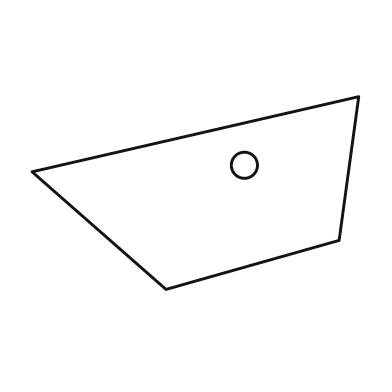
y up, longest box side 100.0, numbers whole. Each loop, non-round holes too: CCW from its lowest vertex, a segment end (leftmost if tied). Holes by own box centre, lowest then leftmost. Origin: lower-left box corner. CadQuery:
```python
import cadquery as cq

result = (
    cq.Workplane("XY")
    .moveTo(41.0, 0.0)
    .lineTo(94.0, 15.0)
    .lineTo(100.0, 59.0)
    .lineTo(0.0, 36.0)
    .close()
    .moveTo(65.0, 38.0)
    .circle(4.0)
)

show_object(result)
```